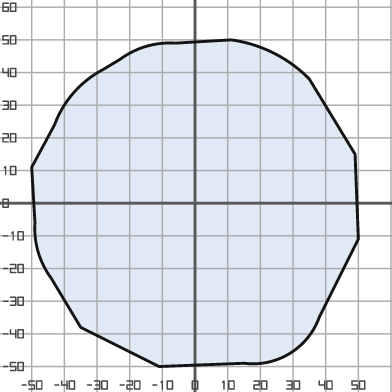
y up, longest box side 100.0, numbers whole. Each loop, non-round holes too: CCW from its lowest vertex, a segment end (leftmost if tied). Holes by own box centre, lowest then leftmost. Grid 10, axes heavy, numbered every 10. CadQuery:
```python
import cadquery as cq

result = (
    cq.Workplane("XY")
    .moveTo(-11.0, -50.0)
    .lineTo(15.0, -49.0)
    .threePointArc((29.0, -46.0), (38.0, -35.0))
    .lineTo(50.0, -11.0)
    .lineTo(49.0, 15.0)
    .lineTo(35.0, 38.0)
    .threePointArc((24.0, 46.0), (11.0, 50.0))
    .lineTo(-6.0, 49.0)
    .threePointArc((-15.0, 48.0), (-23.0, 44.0))
    .lineTo(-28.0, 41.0)
    .threePointArc((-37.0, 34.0), (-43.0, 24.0))
    .lineTo(-50.0, 11.0)
    .lineTo(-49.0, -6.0)
    .threePointArc((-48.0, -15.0), (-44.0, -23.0))
    .lineTo(-35.0, -38.0)
    .close()
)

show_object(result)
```